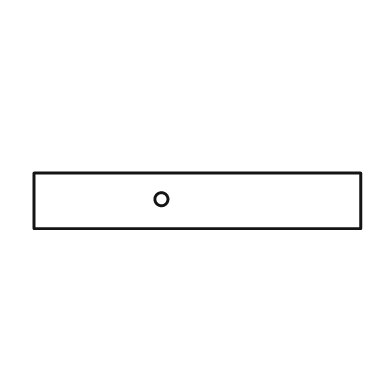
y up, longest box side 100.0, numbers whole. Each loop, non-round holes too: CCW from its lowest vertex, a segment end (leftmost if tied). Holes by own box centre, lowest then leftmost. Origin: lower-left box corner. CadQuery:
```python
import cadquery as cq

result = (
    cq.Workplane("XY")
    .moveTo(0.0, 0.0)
    .lineTo(100.0, 0.0)
    .lineTo(100.0, 17.0)
    .lineTo(0.0, 17.0)
    .close()
    .moveTo(39.0, 9.0)
    .circle(2.0)
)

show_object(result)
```